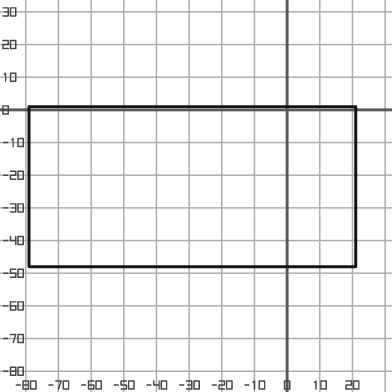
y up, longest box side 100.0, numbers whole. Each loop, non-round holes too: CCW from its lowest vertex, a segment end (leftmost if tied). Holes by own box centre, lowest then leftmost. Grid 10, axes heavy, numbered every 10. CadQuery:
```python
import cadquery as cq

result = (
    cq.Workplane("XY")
    .moveTo(-79.0, -48.0)
    .lineTo(21.0, -48.0)
    .lineTo(21.0, 1.0)
    .lineTo(-79.0, 1.0)
    .close()
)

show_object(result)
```